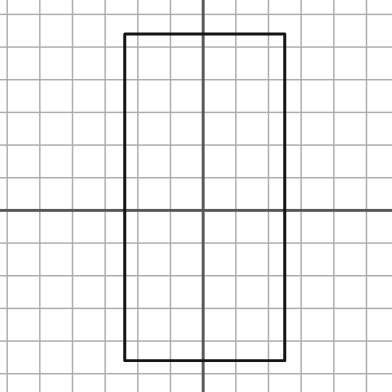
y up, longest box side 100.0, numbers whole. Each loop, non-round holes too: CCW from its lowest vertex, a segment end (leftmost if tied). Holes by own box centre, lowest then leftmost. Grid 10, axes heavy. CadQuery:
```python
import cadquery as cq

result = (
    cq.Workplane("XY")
    .moveTo(-24.0, -46.0)
    .lineTo(25.0, -46.0)
    .lineTo(25.0, 54.0)
    .lineTo(-24.0, 54.0)
    .close()
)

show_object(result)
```